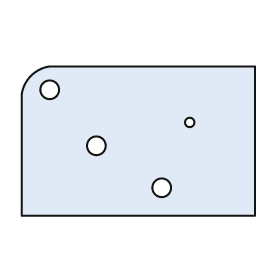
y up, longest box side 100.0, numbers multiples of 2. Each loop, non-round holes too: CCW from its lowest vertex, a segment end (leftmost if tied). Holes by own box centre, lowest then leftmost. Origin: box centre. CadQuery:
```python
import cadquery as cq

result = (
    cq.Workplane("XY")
    .moveTo(-50.0, -32.0)
    .lineTo(50.0, -32.0)
    .lineTo(50.0, 32.0)
    .lineTo(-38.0, 32.0)
    .threePointArc((-46.0, 28.0), (-50.0, 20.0))
    .close()
    .moveTo(10.0, -20.0)
    .circle(4.0)
    .moveTo(-18.0, -2.0)
    .circle(4.0)
    .moveTo(22.0, 8.0)
    .circle(2.0)
    .moveTo(-38.0, 22.0)
    .circle(4.0)
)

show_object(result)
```